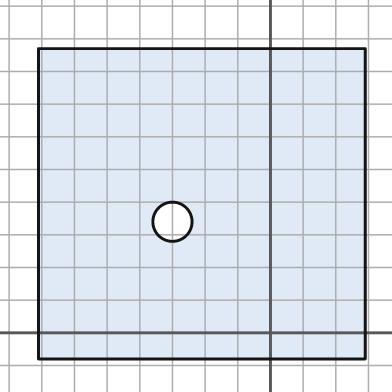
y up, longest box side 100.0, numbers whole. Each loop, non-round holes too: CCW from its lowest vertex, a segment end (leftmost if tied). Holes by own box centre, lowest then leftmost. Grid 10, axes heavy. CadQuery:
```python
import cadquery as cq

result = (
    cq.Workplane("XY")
    .moveTo(-71.0, -8.0)
    .lineTo(29.0, -8.0)
    .lineTo(29.0, 87.0)
    .lineTo(-71.0, 87.0)
    .close()
    .moveTo(-30.0, 34.0)
    .circle(6.0)
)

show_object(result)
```